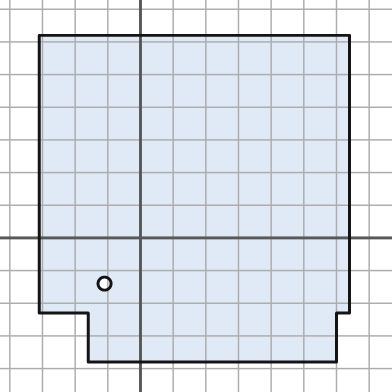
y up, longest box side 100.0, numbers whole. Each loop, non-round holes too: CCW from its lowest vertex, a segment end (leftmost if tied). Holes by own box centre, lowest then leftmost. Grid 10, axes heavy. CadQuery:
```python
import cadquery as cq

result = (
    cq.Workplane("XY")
    .moveTo(-16.0, -38.0)
    .lineTo(60.0, -38.0)
    .lineTo(60.0, -23.0)
    .lineTo(64.0, -23.0)
    .lineTo(64.0, 62.0)
    .lineTo(-31.0, 62.0)
    .lineTo(-31.0, -23.0)
    .lineTo(-16.0, -23.0)
    .close()
    .moveTo(-11.0, -14.0)
    .circle(2.0)
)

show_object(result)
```